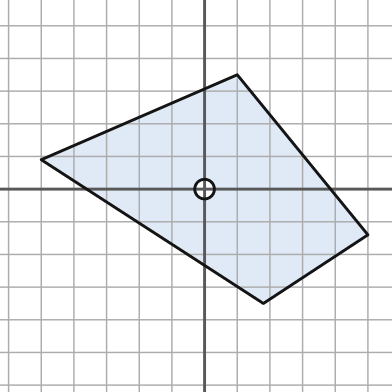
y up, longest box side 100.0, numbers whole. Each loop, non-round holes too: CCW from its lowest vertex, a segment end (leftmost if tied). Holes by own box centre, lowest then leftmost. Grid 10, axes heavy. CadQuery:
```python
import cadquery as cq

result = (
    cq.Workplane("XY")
    .moveTo(18.0, -35.0)
    .lineTo(50.0, -14.0)
    .lineTo(10.0, 35.0)
    .lineTo(-50.0, 9.0)
    .close()
    .moveTo(0.0, 0.0)
    .circle(3.0)
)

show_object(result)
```